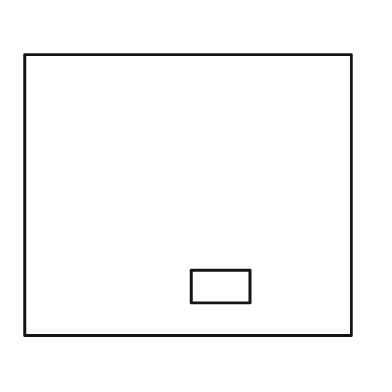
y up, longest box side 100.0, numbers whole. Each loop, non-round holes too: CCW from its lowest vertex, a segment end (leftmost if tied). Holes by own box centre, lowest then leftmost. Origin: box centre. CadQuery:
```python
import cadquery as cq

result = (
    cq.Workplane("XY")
    .moveTo(-50.0, -43.0)
    .lineTo(50.0, -43.0)
    .lineTo(50.0, 43.0)
    .lineTo(-50.0, 43.0)
    .close()
    .moveTo(1.0, -33.0)
    .lineTo(19.0, -33.0)
    .lineTo(19.0, -23.0)
    .lineTo(1.0, -23.0)
    .close()
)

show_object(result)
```